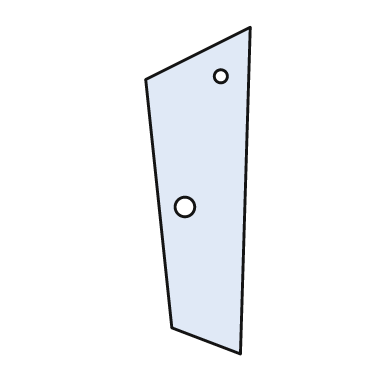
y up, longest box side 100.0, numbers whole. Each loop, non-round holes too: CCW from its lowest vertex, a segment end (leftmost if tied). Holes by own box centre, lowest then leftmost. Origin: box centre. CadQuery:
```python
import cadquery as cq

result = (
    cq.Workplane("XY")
    .moveTo(13.0, -50.0)
    .lineTo(16.0, 50.0)
    .lineTo(-16.0, 34.0)
    .lineTo(-8.0, -42.0)
    .close()
    .moveTo(-4.0, -5.0)
    .circle(3.0)
    .moveTo(7.0, 35.0)
    .circle(2.0)
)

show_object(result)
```